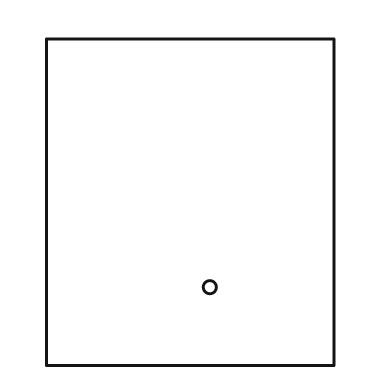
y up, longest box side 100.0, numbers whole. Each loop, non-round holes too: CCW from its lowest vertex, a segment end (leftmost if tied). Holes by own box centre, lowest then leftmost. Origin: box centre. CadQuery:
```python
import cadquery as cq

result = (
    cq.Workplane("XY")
    .moveTo(-44.0, -50.0)
    .lineTo(44.0, -50.0)
    .lineTo(44.0, 50.0)
    .lineTo(-44.0, 50.0)
    .close()
    .moveTo(6.0, -26.0)
    .circle(2.0)
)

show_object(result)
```